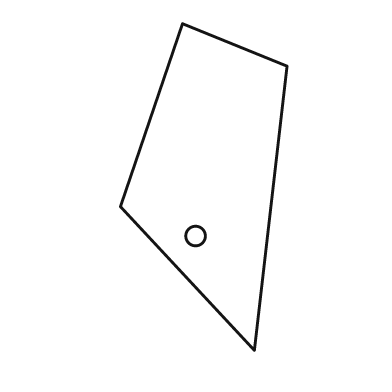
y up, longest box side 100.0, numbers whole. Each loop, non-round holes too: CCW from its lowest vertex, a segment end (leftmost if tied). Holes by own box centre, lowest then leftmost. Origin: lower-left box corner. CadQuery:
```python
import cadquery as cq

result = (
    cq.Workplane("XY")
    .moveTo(41.0, 0.0)
    .lineTo(51.0, 87.0)
    .lineTo(19.0, 100.0)
    .lineTo(0.0, 44.0)
    .close()
    .moveTo(23.0, 35.0)
    .circle(3.0)
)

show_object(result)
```